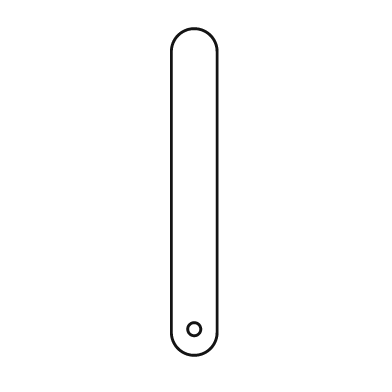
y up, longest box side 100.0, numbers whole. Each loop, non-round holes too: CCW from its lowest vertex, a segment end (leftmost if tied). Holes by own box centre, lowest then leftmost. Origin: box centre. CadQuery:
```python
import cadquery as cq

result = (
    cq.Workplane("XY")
    .moveTo(-7.0, -43.0)
    .threePointArc((0.0, -50.0), (7.0, -43.0))
    .lineTo(7.0, 43.0)
    .threePointArc((0.0, 50.0), (-7.0, 43.0))
    .close()
    .moveTo(0.0, -42.0)
    .circle(2.0)
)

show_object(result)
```